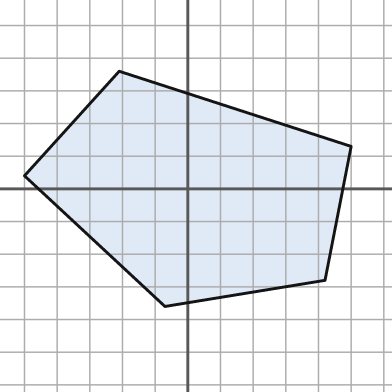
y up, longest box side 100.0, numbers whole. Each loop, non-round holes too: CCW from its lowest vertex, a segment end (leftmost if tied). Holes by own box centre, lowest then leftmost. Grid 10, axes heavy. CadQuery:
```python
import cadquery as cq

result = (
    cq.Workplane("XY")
    .moveTo(-7.0, -36.0)
    .lineTo(42.0, -28.0)
    .lineTo(50.0, 13.0)
    .lineTo(-21.0, 36.0)
    .lineTo(-50.0, 4.0)
    .close()
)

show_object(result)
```